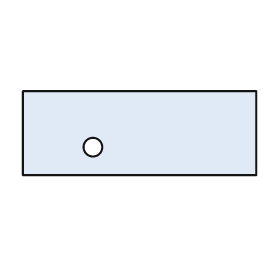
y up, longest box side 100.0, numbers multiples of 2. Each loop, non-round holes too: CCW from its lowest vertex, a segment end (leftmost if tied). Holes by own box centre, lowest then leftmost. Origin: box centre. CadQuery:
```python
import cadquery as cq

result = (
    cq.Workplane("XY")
    .moveTo(-50.0, -18.0)
    .lineTo(50.0, -18.0)
    .lineTo(50.0, 18.0)
    .lineTo(-50.0, 18.0)
    .close()
    .moveTo(-20.0, -6.0)
    .circle(4.0)
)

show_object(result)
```